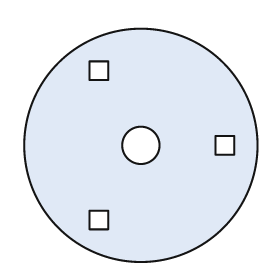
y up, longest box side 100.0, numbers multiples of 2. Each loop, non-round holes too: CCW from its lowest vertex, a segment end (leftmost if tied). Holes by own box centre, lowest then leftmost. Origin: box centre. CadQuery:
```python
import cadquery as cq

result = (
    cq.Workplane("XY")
    .moveTo(0.0, 0.0)
    .circle(50.0)
    .moveTo(-22.0, -36.0)
    .lineTo(-14.0, -36.0)
    .lineTo(-14.0, -28.0)
    .lineTo(-22.0, -28.0)
    .close()
    .moveTo(0.0, 0.0)
    .circle(8.0)
    .moveTo(32.0, -4.0)
    .lineTo(40.0, -4.0)
    .lineTo(40.0, 4.0)
    .lineTo(32.0, 4.0)
    .close()
    .moveTo(-22.0, 28.0)
    .lineTo(-14.0, 28.0)
    .lineTo(-14.0, 36.0)
    .lineTo(-22.0, 36.0)
    .close()
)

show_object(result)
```